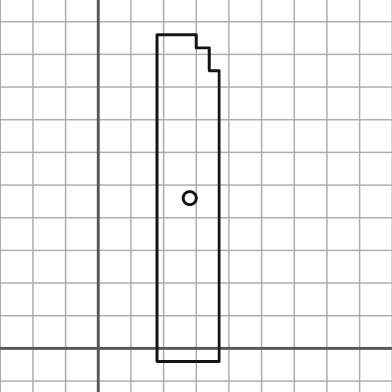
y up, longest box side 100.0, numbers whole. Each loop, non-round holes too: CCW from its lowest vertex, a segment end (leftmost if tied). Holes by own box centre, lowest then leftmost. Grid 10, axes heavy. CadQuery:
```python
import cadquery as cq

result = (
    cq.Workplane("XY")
    .moveTo(18.0, -4.0)
    .lineTo(37.0, -4.0)
    .lineTo(37.0, 85.0)
    .lineTo(34.0, 85.0)
    .lineTo(34.0, 92.0)
    .lineTo(30.0, 92.0)
    .lineTo(30.0, 96.0)
    .lineTo(18.0, 96.0)
    .close()
    .moveTo(28.0, 46.0)
    .circle(2.0)
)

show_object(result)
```